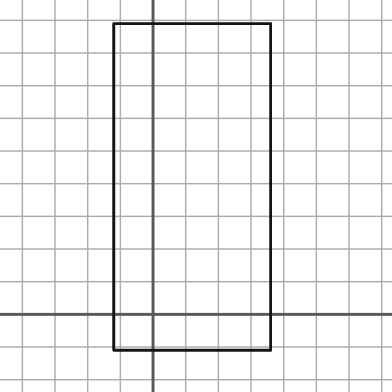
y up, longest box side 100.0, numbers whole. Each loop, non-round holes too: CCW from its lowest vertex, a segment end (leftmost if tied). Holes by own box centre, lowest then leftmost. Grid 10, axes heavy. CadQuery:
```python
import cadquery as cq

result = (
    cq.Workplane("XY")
    .moveTo(-12.0, -11.0)
    .lineTo(36.0, -11.0)
    .lineTo(36.0, 89.0)
    .lineTo(-12.0, 89.0)
    .close()
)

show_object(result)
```